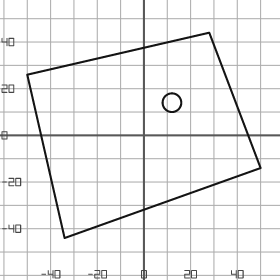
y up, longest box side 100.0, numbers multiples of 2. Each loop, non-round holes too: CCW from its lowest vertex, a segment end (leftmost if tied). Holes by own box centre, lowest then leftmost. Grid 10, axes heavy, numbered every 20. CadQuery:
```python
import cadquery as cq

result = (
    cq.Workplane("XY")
    .moveTo(-34.0, -44.0)
    .lineTo(50.0, -14.0)
    .lineTo(28.0, 44.0)
    .lineTo(-50.0, 26.0)
    .close()
    .moveTo(12.0, 14.0)
    .circle(4.0)
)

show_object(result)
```